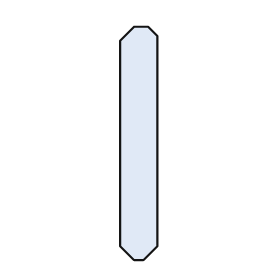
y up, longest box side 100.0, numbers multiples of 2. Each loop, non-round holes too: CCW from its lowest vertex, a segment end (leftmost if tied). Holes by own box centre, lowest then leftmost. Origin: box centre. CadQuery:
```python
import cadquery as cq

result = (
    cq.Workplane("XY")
    .moveTo(-2.0, -50.0)
    .lineTo(2.0, -50.0)
    .lineTo(8.0, -44.0)
    .lineTo(8.0, 46.0)
    .lineTo(4.0, 50.0)
    .lineTo(-2.0, 50.0)
    .lineTo(-8.0, 44.0)
    .lineTo(-8.0, -44.0)
    .close()
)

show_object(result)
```